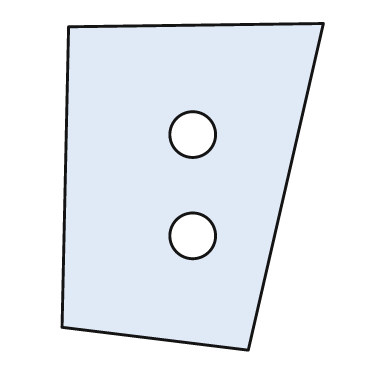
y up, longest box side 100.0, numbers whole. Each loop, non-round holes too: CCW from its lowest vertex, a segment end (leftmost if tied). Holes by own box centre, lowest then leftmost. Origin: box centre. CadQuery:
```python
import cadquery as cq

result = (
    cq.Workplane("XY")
    .moveTo(17.0, -50.0)
    .lineTo(40.0, 50.0)
    .lineTo(-38.0, 49.0)
    .lineTo(-40.0, -43.0)
    .close()
    .moveTo(0.0, -15.0)
    .circle(7.0)
    .moveTo(0.0, 16.0)
    .circle(7.0)
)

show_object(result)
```